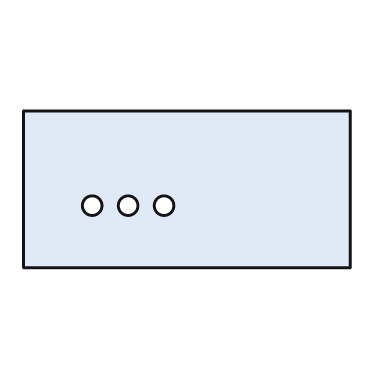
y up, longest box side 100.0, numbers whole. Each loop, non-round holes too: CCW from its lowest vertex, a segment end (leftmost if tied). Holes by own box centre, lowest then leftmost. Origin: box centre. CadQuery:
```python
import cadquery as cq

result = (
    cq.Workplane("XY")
    .moveTo(-50.0, -24.0)
    .lineTo(50.0, -24.0)
    .lineTo(50.0, 24.0)
    .lineTo(-50.0, 24.0)
    .close()
    .moveTo(-29.0, -5.0)
    .circle(3.0)
    .moveTo(-18.0, -5.0)
    .circle(3.0)
    .moveTo(-7.0, -5.0)
    .circle(3.0)
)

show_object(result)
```